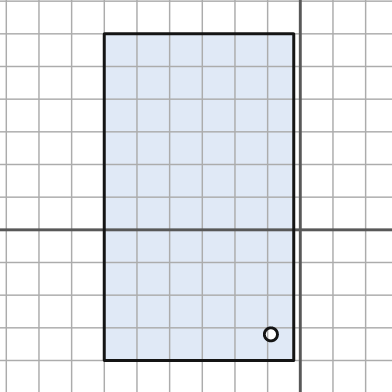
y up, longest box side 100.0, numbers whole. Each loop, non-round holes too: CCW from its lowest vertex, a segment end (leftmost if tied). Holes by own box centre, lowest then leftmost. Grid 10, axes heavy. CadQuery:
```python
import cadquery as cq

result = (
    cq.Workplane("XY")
    .moveTo(-60.0, -40.0)
    .lineTo(-2.0, -40.0)
    .lineTo(-2.0, 60.0)
    .lineTo(-60.0, 60.0)
    .close()
    .moveTo(-9.0, -32.0)
    .circle(2.0)
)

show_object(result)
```